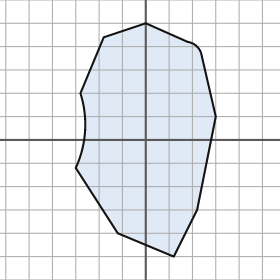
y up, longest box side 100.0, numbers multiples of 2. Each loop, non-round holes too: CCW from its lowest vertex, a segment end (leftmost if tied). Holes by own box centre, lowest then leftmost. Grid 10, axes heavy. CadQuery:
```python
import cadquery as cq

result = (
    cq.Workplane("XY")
    .moveTo(12.0, -50.0)
    .lineTo(22.0, -30.0)
    .lineTo(30.0, 10.0)
    .lineTo(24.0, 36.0)
    .threePointArc((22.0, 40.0), (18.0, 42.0))
    .lineTo(0.0, 50.0)
    .lineTo(-18.0, 44.0)
    .lineTo(-28.0, 20.0)
    .threePointArc((-26.0, 4.0), (-30.0, -12.0))
    .lineTo(-12.0, -40.0)
    .close()
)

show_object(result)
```